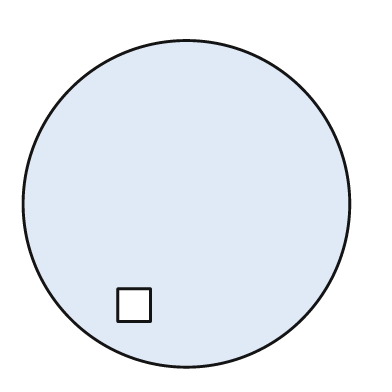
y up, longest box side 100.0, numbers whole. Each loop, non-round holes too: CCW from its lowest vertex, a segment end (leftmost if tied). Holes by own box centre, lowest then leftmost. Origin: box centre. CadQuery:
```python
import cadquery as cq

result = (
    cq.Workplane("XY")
    .moveTo(0.0, 0.0)
    .circle(50.0)
    .moveTo(-21.0, -36.0)
    .lineTo(-11.0, -36.0)
    .lineTo(-11.0, -26.0)
    .lineTo(-21.0, -26.0)
    .close()
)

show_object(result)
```